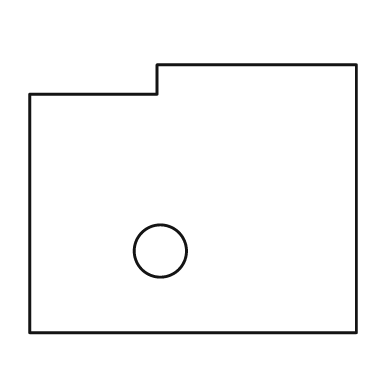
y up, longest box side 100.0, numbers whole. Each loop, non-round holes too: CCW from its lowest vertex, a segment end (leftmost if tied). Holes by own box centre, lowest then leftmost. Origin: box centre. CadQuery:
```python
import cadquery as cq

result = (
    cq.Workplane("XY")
    .moveTo(-50.0, -41.0)
    .lineTo(50.0, -41.0)
    .lineTo(50.0, 41.0)
    .lineTo(-11.0, 41.0)
    .lineTo(-11.0, 32.0)
    .lineTo(-50.0, 32.0)
    .close()
    .moveTo(-10.0, -16.0)
    .circle(8.0)
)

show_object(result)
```